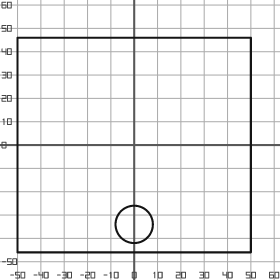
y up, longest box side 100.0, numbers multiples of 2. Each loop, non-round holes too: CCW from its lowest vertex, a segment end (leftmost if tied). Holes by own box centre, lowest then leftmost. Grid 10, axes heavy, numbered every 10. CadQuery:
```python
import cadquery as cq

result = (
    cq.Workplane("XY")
    .moveTo(-50.0, -46.0)
    .lineTo(50.0, -46.0)
    .lineTo(50.0, 46.0)
    .lineTo(-50.0, 46.0)
    .close()
    .moveTo(0.0, -34.0)
    .circle(8.0)
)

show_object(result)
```